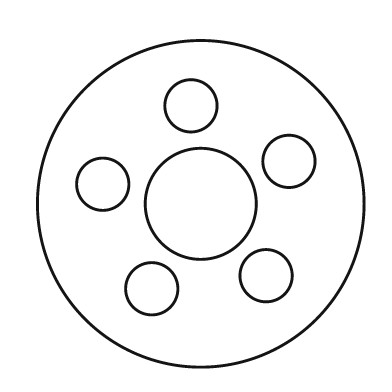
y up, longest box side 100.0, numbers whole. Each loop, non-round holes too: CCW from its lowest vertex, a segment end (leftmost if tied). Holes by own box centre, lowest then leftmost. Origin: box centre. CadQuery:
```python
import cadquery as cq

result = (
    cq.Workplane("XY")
    .moveTo(0.0, 0.0)
    .circle(50.0)
    .moveTo(-15.0, -26.0)
    .circle(8.0)
    .moveTo(20.0, -22.0)
    .circle(8.0)
    .moveTo(0.0, 0.0)
    .circle(17.0)
    .moveTo(-30.0, 6.0)
    .circle(8.0)
    .moveTo(27.0, 13.0)
    .circle(8.0)
    .moveTo(-3.0, 30.0)
    .circle(8.0)
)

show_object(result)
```